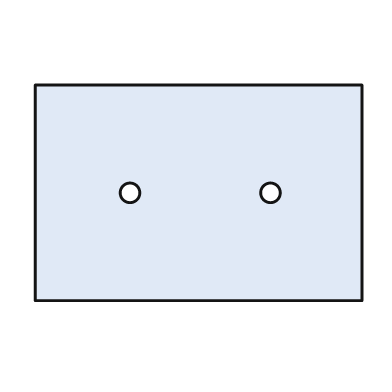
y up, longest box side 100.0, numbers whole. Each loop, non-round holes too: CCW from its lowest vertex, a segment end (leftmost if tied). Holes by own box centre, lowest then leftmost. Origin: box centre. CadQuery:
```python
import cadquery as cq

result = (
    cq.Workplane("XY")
    .moveTo(-50.0, -33.0)
    .lineTo(50.0, -33.0)
    .lineTo(50.0, 33.0)
    .lineTo(-50.0, 33.0)
    .close()
    .moveTo(-21.0, 0.0)
    .circle(3.0)
    .moveTo(22.0, 0.0)
    .circle(3.0)
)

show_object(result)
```